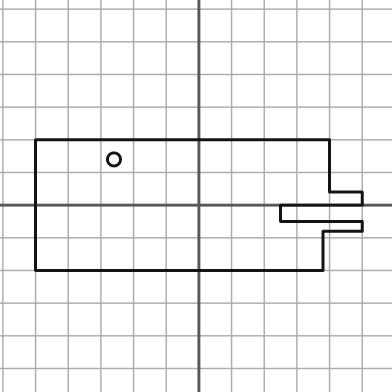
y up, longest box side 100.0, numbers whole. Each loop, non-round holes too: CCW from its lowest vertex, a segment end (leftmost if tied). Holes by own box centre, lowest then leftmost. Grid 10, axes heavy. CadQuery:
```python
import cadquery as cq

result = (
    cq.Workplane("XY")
    .moveTo(-50.0, -20.0)
    .lineTo(38.0, -20.0)
    .lineTo(38.0, -8.0)
    .lineTo(50.0, -8.0)
    .lineTo(50.0, -5.0)
    .lineTo(25.0, -5.0)
    .lineTo(25.0, 0.0)
    .lineTo(50.0, 0.0)
    .lineTo(50.0, 4.0)
    .lineTo(40.0, 4.0)
    .lineTo(40.0, 20.0)
    .lineTo(-50.0, 20.0)
    .close()
    .moveTo(-26.0, 14.0)
    .circle(2.0)
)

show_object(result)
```